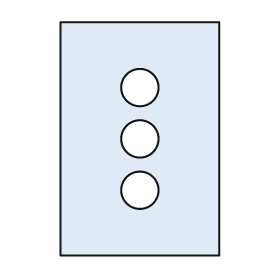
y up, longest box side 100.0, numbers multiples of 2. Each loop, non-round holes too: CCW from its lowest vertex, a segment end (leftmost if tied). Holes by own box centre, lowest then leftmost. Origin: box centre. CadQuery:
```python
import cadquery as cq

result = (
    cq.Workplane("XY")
    .moveTo(-34.0, -50.0)
    .lineTo(34.0, -50.0)
    .lineTo(34.0, 50.0)
    .lineTo(-34.0, 50.0)
    .close()
    .moveTo(0.0, -22.0)
    .circle(8.0)
    .moveTo(0.0, 0.0)
    .circle(8.0)
    .moveTo(0.0, 22.0)
    .circle(8.0)
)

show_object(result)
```